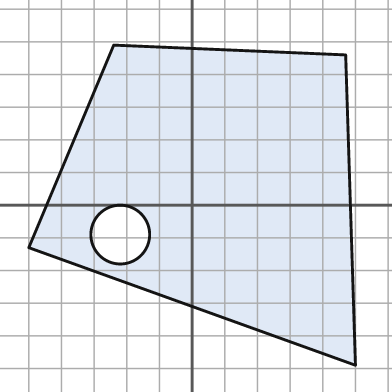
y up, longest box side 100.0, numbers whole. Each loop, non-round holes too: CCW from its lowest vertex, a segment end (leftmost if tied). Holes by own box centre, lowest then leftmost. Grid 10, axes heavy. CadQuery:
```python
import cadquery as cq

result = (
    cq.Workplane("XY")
    .moveTo(50.0, -49.0)
    .lineTo(47.0, 46.0)
    .lineTo(-24.0, 49.0)
    .lineTo(-50.0, -13.0)
    .close()
    .moveTo(-22.0, -9.0)
    .circle(9.0)
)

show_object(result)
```